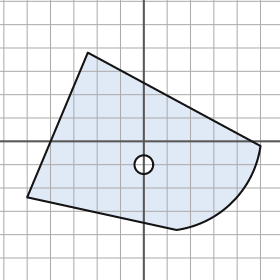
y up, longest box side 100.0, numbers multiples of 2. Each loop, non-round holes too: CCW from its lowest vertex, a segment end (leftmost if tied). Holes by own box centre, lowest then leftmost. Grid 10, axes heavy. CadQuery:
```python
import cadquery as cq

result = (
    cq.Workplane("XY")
    .moveTo(14.0, -38.0)
    .threePointArc((38.0, -26.0), (50.0, -2.0))
    .lineTo(-24.0, 38.0)
    .lineTo(-50.0, -24.0)
    .close()
    .moveTo(0.0, -10.0)
    .circle(4.0)
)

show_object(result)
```